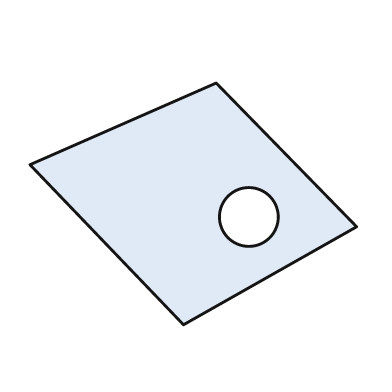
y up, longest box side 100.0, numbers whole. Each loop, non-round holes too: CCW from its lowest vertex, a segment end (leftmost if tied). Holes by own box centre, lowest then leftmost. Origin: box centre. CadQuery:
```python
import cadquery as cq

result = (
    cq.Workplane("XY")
    .moveTo(-3.0, -37.0)
    .lineTo(50.0, -7.0)
    .lineTo(7.0, 37.0)
    .lineTo(-50.0, 12.0)
    .close()
    .moveTo(17.0, -4.0)
    .circle(9.0)
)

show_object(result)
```